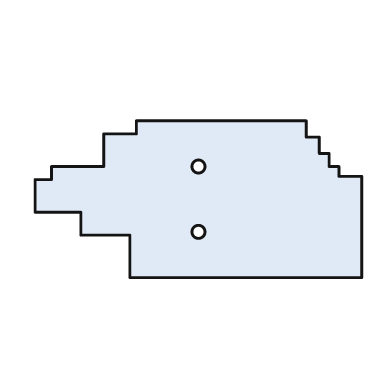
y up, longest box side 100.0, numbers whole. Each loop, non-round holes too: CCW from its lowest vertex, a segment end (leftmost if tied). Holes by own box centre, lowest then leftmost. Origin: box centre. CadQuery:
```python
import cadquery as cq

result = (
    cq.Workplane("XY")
    .moveTo(-21.0, -24.0)
    .lineTo(50.0, -24.0)
    .lineTo(50.0, 7.0)
    .lineTo(43.0, 7.0)
    .lineTo(43.0, 10.0)
    .lineTo(40.0, 10.0)
    .lineTo(40.0, 14.0)
    .lineTo(37.0, 14.0)
    .lineTo(37.0, 19.0)
    .lineTo(33.0, 19.0)
    .lineTo(33.0, 24.0)
    .lineTo(-19.0, 24.0)
    .lineTo(-19.0, 20.0)
    .lineTo(-29.0, 20.0)
    .lineTo(-29.0, 10.0)
    .lineTo(-45.0, 10.0)
    .lineTo(-45.0, 6.0)
    .lineTo(-50.0, 6.0)
    .lineTo(-50.0, -4.0)
    .lineTo(-36.0, -4.0)
    .lineTo(-36.0, -11.0)
    .lineTo(-21.0, -11.0)
    .close()
    .moveTo(0.0, -10.0)
    .circle(2.0)
    .moveTo(0.0, 10.0)
    .circle(2.0)
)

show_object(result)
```